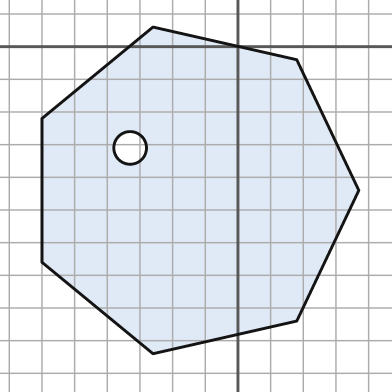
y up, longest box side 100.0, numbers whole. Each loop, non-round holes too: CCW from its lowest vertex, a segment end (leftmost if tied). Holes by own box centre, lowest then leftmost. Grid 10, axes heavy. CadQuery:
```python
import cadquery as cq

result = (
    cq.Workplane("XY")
    .moveTo(-26.0, -94.0)
    .lineTo(18.0, -84.0)
    .lineTo(37.0, -44.0)
    .lineTo(18.0, -4.0)
    .lineTo(-26.0, 6.0)
    .lineTo(-60.0, -22.0)
    .lineTo(-60.0, -66.0)
    .close()
    .moveTo(-33.0, -31.0)
    .circle(5.0)
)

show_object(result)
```